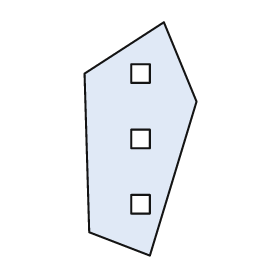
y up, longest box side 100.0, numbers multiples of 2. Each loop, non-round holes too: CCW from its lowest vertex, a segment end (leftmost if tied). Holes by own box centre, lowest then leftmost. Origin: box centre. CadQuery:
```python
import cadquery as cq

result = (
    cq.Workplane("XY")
    .moveTo(4.0, -50.0)
    .lineTo(24.0, 16.0)
    .lineTo(10.0, 50.0)
    .lineTo(-24.0, 28.0)
    .lineTo(-22.0, -40.0)
    .close()
    .moveTo(-4.0, -32.0)
    .lineTo(4.0, -32.0)
    .lineTo(4.0, -24.0)
    .lineTo(-4.0, -24.0)
    .close()
    .moveTo(-4.0, -4.0)
    .lineTo(4.0, -4.0)
    .lineTo(4.0, 4.0)
    .lineTo(-4.0, 4.0)
    .close()
    .moveTo(-4.0, 24.0)
    .lineTo(4.0, 24.0)
    .lineTo(4.0, 32.0)
    .lineTo(-4.0, 32.0)
    .close()
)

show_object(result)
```